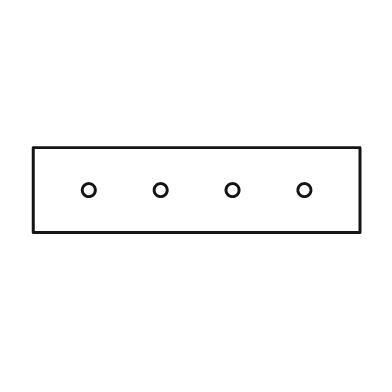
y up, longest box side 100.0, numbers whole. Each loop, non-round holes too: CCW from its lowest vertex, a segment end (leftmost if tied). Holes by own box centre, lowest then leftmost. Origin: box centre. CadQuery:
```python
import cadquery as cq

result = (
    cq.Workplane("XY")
    .moveTo(-50.0, -13.0)
    .lineTo(50.0, -13.0)
    .lineTo(50.0, 13.0)
    .lineTo(-50.0, 13.0)
    .close()
    .moveTo(-33.0, 0.0)
    .circle(2.0)
    .moveTo(-11.0, 0.0)
    .circle(2.0)
    .moveTo(11.0, 0.0)
    .circle(2.0)
    .moveTo(33.0, 0.0)
    .circle(2.0)
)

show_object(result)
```